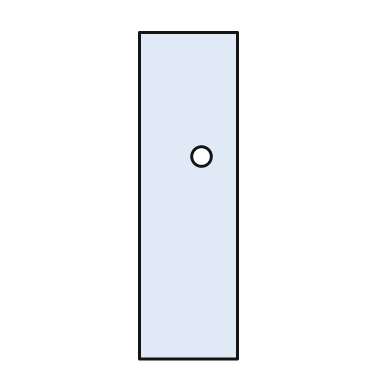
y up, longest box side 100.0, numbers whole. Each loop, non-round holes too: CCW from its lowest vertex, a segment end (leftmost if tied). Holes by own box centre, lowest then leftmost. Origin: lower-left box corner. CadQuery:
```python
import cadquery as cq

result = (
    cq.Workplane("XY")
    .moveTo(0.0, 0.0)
    .lineTo(30.0, 0.0)
    .lineTo(30.0, 100.0)
    .lineTo(0.0, 100.0)
    .close()
    .moveTo(19.0, 62.0)
    .circle(3.0)
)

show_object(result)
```